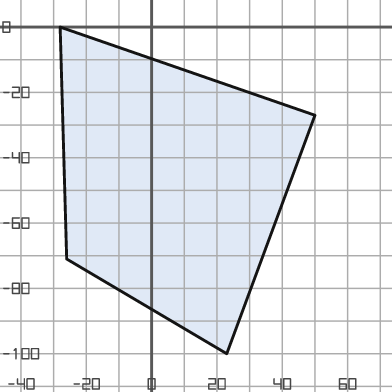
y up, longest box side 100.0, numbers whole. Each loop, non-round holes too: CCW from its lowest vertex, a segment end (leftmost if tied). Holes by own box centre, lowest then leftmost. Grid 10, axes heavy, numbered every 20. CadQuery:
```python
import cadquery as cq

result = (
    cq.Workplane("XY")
    .moveTo(23.0, -100.0)
    .lineTo(50.0, -27.0)
    .lineTo(-28.0, 0.0)
    .lineTo(-26.0, -71.0)
    .close()
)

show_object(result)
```